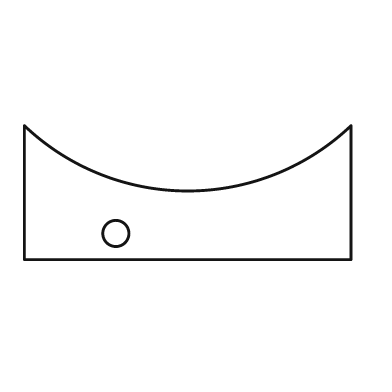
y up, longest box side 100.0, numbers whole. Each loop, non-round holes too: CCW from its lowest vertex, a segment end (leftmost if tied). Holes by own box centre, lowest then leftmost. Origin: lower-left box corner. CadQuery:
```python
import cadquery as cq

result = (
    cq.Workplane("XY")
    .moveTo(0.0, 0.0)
    .lineTo(100.0, 0.0)
    .lineTo(100.0, 41.0)
    .threePointArc((50.0, 21.0), (0.0, 41.0))
    .close()
    .moveTo(28.0, 8.0)
    .circle(4.0)
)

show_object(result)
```